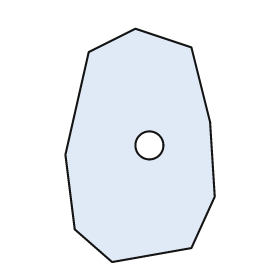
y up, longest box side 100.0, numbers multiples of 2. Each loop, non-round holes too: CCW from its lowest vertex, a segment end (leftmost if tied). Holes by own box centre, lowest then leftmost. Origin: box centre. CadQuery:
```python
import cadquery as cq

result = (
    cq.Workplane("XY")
    .moveTo(-12.0, -50.0)
    .lineTo(22.0, -44.0)
    .lineTo(32.0, -22.0)
    .lineTo(30.0, 10.0)
    .lineTo(22.0, 42.0)
    .lineTo(-2.0, 50.0)
    .lineTo(-22.0, 40.0)
    .lineTo(-32.0, -4.0)
    .lineTo(-28.0, -36.0)
    .close()
    .moveTo(4.0, 0.0)
    .circle(6.0)
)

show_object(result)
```